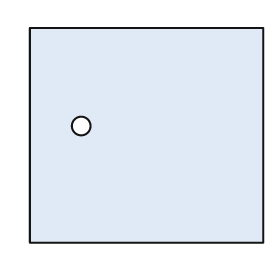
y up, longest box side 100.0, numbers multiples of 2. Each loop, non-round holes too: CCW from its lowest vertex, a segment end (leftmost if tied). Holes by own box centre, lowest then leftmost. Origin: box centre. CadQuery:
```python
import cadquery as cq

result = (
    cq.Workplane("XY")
    .moveTo(-50.0, -46.0)
    .lineTo(50.0, -46.0)
    .lineTo(50.0, 46.0)
    .lineTo(-50.0, 46.0)
    .close()
    .moveTo(-28.0, 4.0)
    .circle(4.0)
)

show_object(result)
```